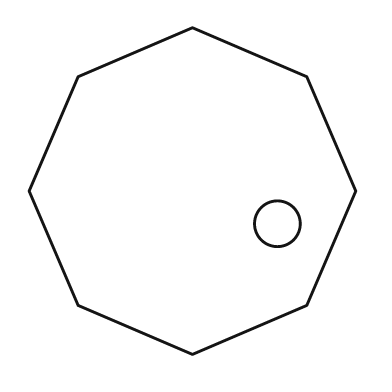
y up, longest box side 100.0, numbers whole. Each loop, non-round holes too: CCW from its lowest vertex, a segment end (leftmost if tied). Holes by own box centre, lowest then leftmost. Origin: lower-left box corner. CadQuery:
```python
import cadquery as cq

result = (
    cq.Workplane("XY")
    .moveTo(50.0, 0.0)
    .lineTo(85.0, 15.0)
    .lineTo(100.0, 50.0)
    .lineTo(85.0, 85.0)
    .lineTo(50.0, 100.0)
    .lineTo(15.0, 85.0)
    .lineTo(0.0, 50.0)
    .lineTo(15.0, 15.0)
    .close()
    .moveTo(76.0, 40.0)
    .circle(7.0)
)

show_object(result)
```